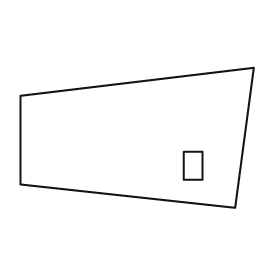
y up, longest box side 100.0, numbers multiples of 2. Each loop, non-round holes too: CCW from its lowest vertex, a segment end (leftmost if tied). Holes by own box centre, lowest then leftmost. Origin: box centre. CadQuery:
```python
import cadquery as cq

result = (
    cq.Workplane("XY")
    .moveTo(42.0, -30.0)
    .lineTo(50.0, 30.0)
    .lineTo(-50.0, 18.0)
    .lineTo(-50.0, -20.0)
    .close()
    .moveTo(20.0, -18.0)
    .lineTo(28.0, -18.0)
    .lineTo(28.0, -6.0)
    .lineTo(20.0, -6.0)
    .close()
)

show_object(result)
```